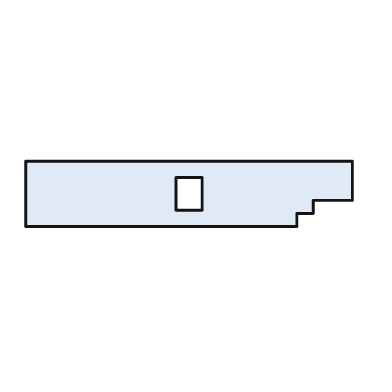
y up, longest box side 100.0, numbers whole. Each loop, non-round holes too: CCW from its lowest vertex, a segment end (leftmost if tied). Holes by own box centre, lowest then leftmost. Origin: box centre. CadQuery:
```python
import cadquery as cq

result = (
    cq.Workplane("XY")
    .moveTo(-50.0, -10.0)
    .lineTo(33.0, -10.0)
    .lineTo(33.0, -6.0)
    .lineTo(38.0, -6.0)
    .lineTo(38.0, -2.0)
    .lineTo(50.0, -2.0)
    .lineTo(50.0, 10.0)
    .lineTo(-50.0, 10.0)
    .close()
    .moveTo(-4.0, -5.0)
    .lineTo(4.0, -5.0)
    .lineTo(4.0, 5.0)
    .lineTo(-4.0, 5.0)
    .close()
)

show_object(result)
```